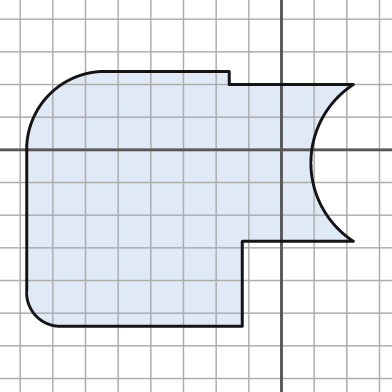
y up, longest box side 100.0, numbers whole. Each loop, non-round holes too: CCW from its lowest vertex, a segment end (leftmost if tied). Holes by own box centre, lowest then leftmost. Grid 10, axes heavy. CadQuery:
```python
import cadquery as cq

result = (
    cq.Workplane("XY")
    .moveTo(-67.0, -54.0)
    .lineTo(-12.0, -54.0)
    .lineTo(-12.0, -28.0)
    .lineTo(22.0, -28.0)
    .threePointArc((9.0, -4.0), (22.0, 20.0))
    .lineTo(-16.0, 20.0)
    .lineTo(-16.0, 24.0)
    .lineTo(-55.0, 24.0)
    .threePointArc((-71.0, 17.0), (-78.0, 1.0))
    .lineTo(-78.0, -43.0)
    .threePointArc((-75.0, -51.0), (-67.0, -54.0))
    .close()
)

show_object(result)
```